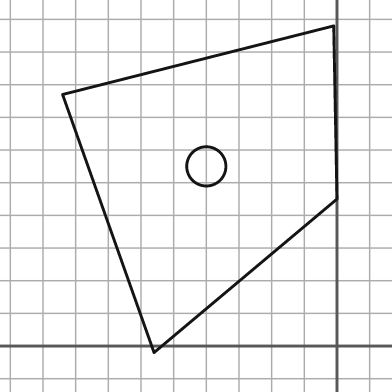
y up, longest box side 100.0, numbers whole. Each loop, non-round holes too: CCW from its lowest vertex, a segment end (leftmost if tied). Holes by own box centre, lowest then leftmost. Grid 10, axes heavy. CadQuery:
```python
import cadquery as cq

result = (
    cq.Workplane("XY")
    .moveTo(-56.0, -2.0)
    .lineTo(0.0, 45.0)
    .lineTo(-1.0, 98.0)
    .lineTo(-84.0, 77.0)
    .close()
    .moveTo(-40.0, 55.0)
    .circle(6.0)
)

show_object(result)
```